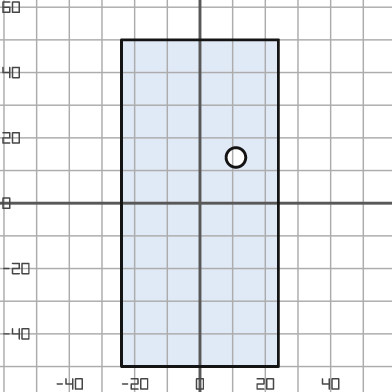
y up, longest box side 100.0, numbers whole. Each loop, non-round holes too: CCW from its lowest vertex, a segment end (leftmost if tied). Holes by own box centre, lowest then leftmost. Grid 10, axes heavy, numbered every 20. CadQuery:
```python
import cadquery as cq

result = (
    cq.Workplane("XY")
    .moveTo(-24.0, -50.0)
    .lineTo(24.0, -50.0)
    .lineTo(24.0, 50.0)
    .lineTo(-24.0, 50.0)
    .close()
    .moveTo(11.0, 14.0)
    .circle(3.0)
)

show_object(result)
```